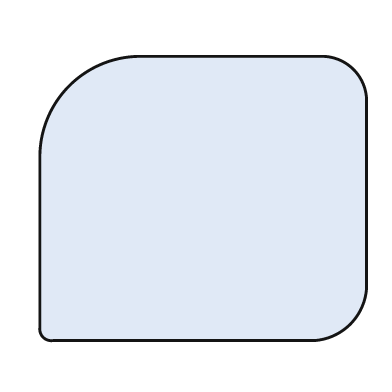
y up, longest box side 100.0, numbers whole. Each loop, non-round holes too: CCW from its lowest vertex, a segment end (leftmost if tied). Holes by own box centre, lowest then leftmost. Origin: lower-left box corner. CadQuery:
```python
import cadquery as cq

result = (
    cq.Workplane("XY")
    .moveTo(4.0, 0.0)
    .lineTo(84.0, 0.0)
    .threePointArc((95.0, 5.0), (100.0, 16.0))
    .lineTo(100.0, 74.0)
    .threePointArc((96.0, 83.0), (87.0, 87.0))
    .lineTo(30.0, 87.0)
    .threePointArc((9.0, 78.0), (0.0, 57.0))
    .lineTo(0.0, 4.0)
    .threePointArc((1.0, 1.0), (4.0, 0.0))
    .close()
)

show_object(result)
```